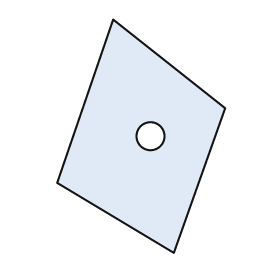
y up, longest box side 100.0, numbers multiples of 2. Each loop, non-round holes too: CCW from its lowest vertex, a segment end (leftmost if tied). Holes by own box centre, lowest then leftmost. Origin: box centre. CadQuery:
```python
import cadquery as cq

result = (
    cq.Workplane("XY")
    .moveTo(14.0, -50.0)
    .lineTo(36.0, 12.0)
    .lineTo(-12.0, 50.0)
    .lineTo(-36.0, -20.0)
    .close()
    .moveTo(4.0, 0.0)
    .circle(6.0)
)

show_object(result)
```